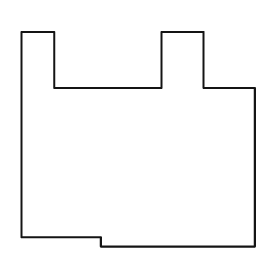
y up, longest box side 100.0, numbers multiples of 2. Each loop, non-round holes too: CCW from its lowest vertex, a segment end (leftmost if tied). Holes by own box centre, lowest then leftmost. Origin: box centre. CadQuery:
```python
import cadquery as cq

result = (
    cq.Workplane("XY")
    .moveTo(-16.0, -46.0)
    .lineTo(50.0, -46.0)
    .lineTo(50.0, 22.0)
    .lineTo(28.0, 22.0)
    .lineTo(28.0, 46.0)
    .lineTo(10.0, 46.0)
    .lineTo(10.0, 22.0)
    .lineTo(-36.0, 22.0)
    .lineTo(-36.0, 46.0)
    .lineTo(-50.0, 46.0)
    .lineTo(-50.0, -42.0)
    .lineTo(-16.0, -42.0)
    .close()
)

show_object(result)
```